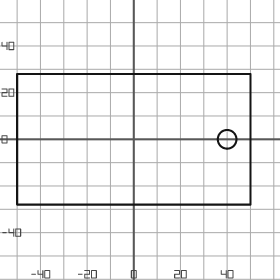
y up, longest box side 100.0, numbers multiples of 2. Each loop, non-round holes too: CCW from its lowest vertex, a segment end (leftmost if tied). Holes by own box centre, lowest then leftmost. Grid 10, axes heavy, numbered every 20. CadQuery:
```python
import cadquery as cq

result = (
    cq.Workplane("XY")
    .moveTo(-50.0, -28.0)
    .lineTo(50.0, -28.0)
    .lineTo(50.0, 28.0)
    .lineTo(-50.0, 28.0)
    .close()
    .moveTo(40.0, 0.0)
    .circle(4.0)
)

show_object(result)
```